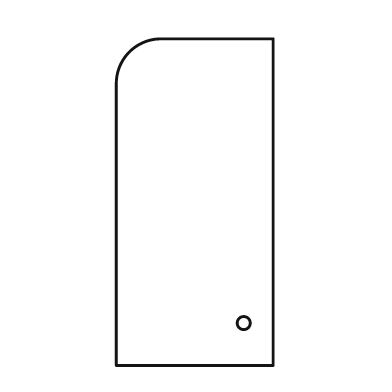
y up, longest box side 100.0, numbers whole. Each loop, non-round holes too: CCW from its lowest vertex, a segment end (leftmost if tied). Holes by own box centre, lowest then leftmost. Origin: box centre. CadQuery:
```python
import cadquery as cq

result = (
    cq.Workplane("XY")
    .moveTo(-24.0, -50.0)
    .lineTo(24.0, -50.0)
    .lineTo(24.0, 50.0)
    .lineTo(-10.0, 50.0)
    .threePointArc((-20.0, 46.0), (-24.0, 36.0))
    .close()
    .moveTo(15.0, -37.0)
    .circle(2.0)
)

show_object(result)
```